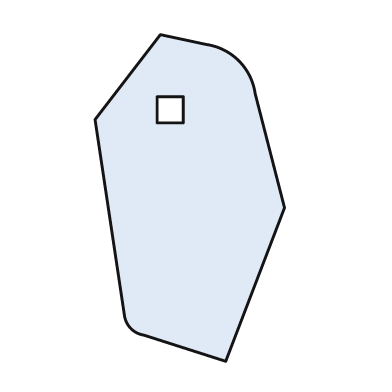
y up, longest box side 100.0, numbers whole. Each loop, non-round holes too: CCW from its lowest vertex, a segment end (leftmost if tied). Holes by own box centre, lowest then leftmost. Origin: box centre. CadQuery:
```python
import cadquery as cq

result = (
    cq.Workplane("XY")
    .moveTo(11.0, -50.0)
    .lineTo(29.0, -3.0)
    .lineTo(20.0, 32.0)
    .threePointArc((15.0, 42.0), (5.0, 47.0))
    .lineTo(-9.0, 50.0)
    .lineTo(-29.0, 24.0)
    .lineTo(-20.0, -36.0)
    .threePointArc((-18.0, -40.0), (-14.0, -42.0))
    .close()
    .moveTo(-10.0, 23.0)
    .lineTo(-2.0, 23.0)
    .lineTo(-2.0, 31.0)
    .lineTo(-10.0, 31.0)
    .close()
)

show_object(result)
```